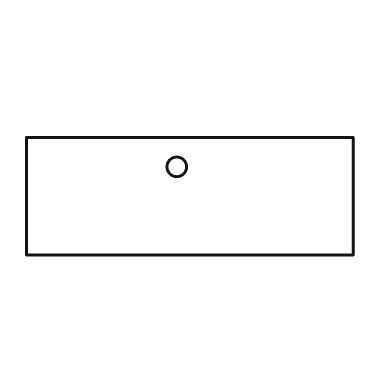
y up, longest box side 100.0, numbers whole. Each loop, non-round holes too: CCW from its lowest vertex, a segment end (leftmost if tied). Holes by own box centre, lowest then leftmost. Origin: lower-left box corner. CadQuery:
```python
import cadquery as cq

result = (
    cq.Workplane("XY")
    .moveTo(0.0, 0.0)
    .lineTo(100.0, 0.0)
    .lineTo(100.0, 36.0)
    .lineTo(0.0, 36.0)
    .close()
    .moveTo(46.0, 27.0)
    .circle(3.0)
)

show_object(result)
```